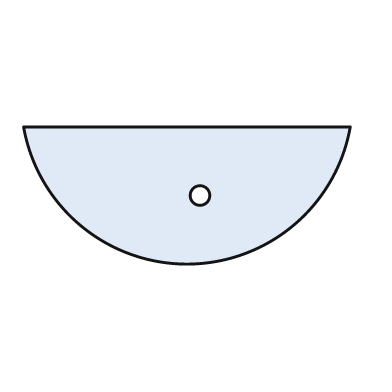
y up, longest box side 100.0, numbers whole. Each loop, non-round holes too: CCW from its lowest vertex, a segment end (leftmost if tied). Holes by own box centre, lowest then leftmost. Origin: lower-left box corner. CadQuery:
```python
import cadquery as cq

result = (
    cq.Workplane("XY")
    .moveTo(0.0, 42.0)
    .threePointArc((50.0, 0.0), (100.0, 42.0))
    .close()
    .moveTo(54.0, 21.0)
    .circle(3.0)
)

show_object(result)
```